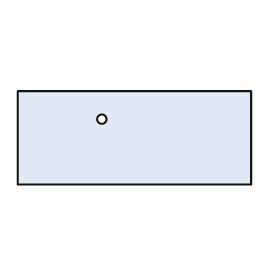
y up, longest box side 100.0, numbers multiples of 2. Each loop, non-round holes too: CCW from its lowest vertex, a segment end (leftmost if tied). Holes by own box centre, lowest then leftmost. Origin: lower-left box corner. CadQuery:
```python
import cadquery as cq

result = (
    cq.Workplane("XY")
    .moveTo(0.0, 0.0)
    .lineTo(100.0, 0.0)
    .lineTo(100.0, 40.0)
    .lineTo(0.0, 40.0)
    .close()
    .moveTo(36.0, 28.0)
    .circle(2.0)
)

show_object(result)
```